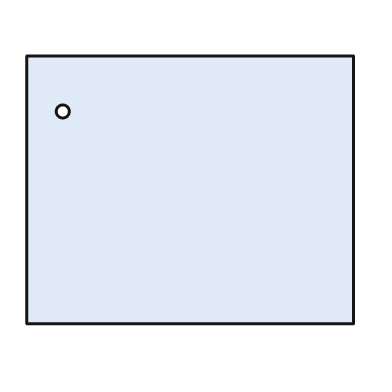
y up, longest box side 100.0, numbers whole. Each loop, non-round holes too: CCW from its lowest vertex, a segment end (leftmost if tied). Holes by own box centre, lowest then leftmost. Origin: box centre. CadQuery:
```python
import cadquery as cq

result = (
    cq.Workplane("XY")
    .moveTo(-50.0, -41.0)
    .lineTo(50.0, -41.0)
    .lineTo(50.0, 41.0)
    .lineTo(-50.0, 41.0)
    .close()
    .moveTo(-39.0, 24.0)
    .circle(2.0)
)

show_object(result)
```